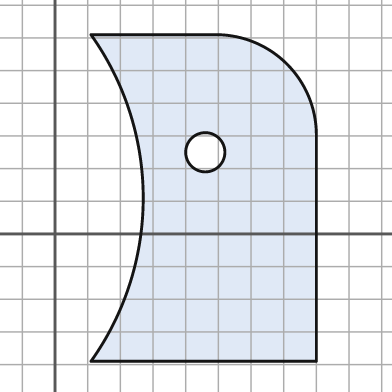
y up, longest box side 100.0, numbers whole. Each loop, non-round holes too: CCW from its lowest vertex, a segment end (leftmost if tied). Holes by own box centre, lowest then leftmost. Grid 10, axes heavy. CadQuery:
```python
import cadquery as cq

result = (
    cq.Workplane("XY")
    .moveTo(11.0, -39.0)
    .lineTo(80.0, -39.0)
    .lineTo(80.0, 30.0)
    .threePointArc((71.0, 52.0), (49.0, 61.0))
    .lineTo(11.0, 61.0)
    .threePointArc((27.0, 11.0), (11.0, -39.0))
    .close()
    .moveTo(46.0, 25.0)
    .circle(6.0)
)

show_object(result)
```